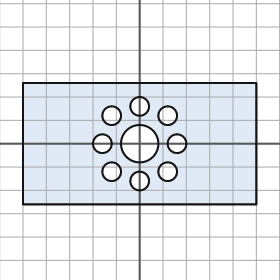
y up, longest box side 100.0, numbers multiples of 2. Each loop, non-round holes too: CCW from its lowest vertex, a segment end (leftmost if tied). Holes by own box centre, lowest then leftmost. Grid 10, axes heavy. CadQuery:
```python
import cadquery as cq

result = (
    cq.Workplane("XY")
    .moveTo(-50.0, -26.0)
    .lineTo(50.0, -26.0)
    .lineTo(50.0, 26.0)
    .lineTo(-50.0, 26.0)
    .close()
    .moveTo(0.0, -16.0)
    .circle(4.0)
    .moveTo(-12.0, -12.0)
    .circle(4.0)
    .moveTo(12.0, -12.0)
    .circle(4.0)
    .moveTo(-16.0, 0.0)
    .circle(4.0)
    .moveTo(0.0, 0.0)
    .circle(8.0)
    .moveTo(16.0, 0.0)
    .circle(4.0)
    .moveTo(-12.0, 12.0)
    .circle(4.0)
    .moveTo(12.0, 12.0)
    .circle(4.0)
    .moveTo(0.0, 16.0)
    .circle(4.0)
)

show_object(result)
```